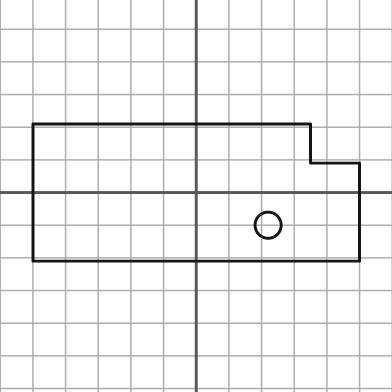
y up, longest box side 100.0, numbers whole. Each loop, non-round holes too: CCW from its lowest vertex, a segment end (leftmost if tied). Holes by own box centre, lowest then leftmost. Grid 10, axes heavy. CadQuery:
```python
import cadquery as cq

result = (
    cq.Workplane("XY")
    .moveTo(-50.0, -21.0)
    .lineTo(50.0, -21.0)
    .lineTo(50.0, 9.0)
    .lineTo(35.0, 9.0)
    .lineTo(35.0, 21.0)
    .lineTo(-50.0, 21.0)
    .close()
    .moveTo(22.0, -10.0)
    .circle(4.0)
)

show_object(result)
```